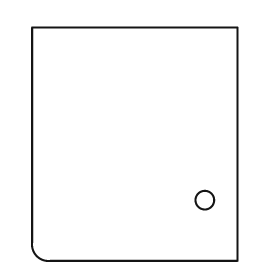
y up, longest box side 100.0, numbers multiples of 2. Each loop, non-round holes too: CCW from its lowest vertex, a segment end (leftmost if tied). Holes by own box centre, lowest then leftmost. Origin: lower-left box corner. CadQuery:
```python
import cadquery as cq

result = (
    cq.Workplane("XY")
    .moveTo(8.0, 0.0)
    .lineTo(88.0, 0.0)
    .lineTo(88.0, 100.0)
    .lineTo(0.0, 100.0)
    .lineTo(0.0, 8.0)
    .threePointArc((2.0, 2.0), (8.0, 0.0))
    .close()
    .moveTo(74.0, 26.0)
    .circle(4.0)
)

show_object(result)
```